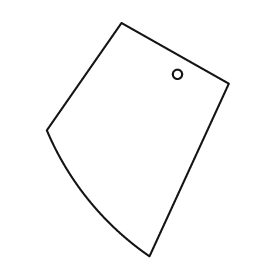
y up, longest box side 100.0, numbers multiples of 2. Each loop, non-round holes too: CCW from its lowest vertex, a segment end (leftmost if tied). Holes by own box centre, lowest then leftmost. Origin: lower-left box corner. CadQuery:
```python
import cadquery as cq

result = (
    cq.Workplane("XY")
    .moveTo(44.0, 0.0)
    .lineTo(78.0, 74.0)
    .lineTo(32.0, 100.0)
    .lineTo(0.0, 54.0)
    .threePointArc((18.0, 24.0), (44.0, 0.0))
    .close()
    .moveTo(56.0, 78.0)
    .circle(2.0)
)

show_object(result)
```